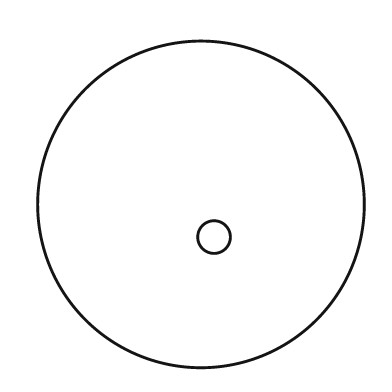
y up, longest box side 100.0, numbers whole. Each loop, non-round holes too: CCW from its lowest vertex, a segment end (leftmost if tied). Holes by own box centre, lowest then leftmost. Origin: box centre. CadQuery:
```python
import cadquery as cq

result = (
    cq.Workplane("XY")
    .moveTo(0.0, 0.0)
    .circle(50.0)
    .moveTo(4.0, -10.0)
    .circle(5.0)
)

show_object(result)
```